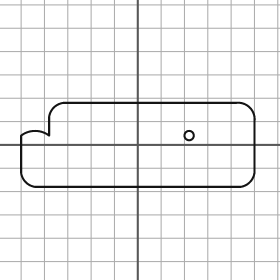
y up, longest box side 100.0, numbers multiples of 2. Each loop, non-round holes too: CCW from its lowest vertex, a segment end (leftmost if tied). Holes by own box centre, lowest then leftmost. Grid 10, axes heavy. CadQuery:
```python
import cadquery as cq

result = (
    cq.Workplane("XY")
    .moveTo(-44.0, -18.0)
    .lineTo(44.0, -18.0)
    .threePointArc((48.0, -16.0), (50.0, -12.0))
    .lineTo(50.0, 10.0)
    .threePointArc((48.0, 16.0), (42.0, 18.0))
    .lineTo(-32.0, 18.0)
    .threePointArc((-36.0, 16.0), (-38.0, 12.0))
    .lineTo(-38.0, 4.0)
    .threePointArc((-44.0, 6.0), (-50.0, 4.0))
    .lineTo(-50.0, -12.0)
    .threePointArc((-48.0, -16.0), (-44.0, -18.0))
    .close()
    .moveTo(22.0, 4.0)
    .circle(2.0)
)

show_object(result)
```